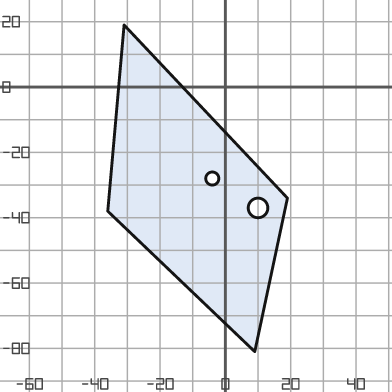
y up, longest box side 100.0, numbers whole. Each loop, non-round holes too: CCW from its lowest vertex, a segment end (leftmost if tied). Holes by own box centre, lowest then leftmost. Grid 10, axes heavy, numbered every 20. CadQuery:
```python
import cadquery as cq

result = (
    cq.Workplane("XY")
    .moveTo(9.0, -81.0)
    .lineTo(19.0, -34.0)
    .lineTo(-31.0, 19.0)
    .lineTo(-36.0, -38.0)
    .close()
    .moveTo(10.0, -37.0)
    .circle(3.0)
    .moveTo(-4.0, -28.0)
    .circle(2.0)
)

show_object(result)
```